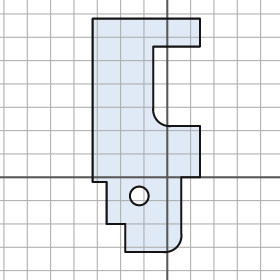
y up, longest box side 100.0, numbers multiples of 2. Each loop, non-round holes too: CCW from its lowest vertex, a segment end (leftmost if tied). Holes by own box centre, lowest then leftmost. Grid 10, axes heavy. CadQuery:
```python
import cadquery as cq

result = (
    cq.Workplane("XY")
    .moveTo(-18.0, -32.0)
    .lineTo(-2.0, -32.0)
    .threePointArc((4.0, -30.0), (6.0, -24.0))
    .lineTo(6.0, 0.0)
    .lineTo(14.0, 0.0)
    .lineTo(14.0, 22.0)
    .lineTo(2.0, 22.0)
    .threePointArc((-4.0, 24.0), (-6.0, 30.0))
    .lineTo(-6.0, 56.0)
    .lineTo(14.0, 56.0)
    .lineTo(14.0, 68.0)
    .lineTo(-32.0, 68.0)
    .lineTo(-32.0, -2.0)
    .lineTo(-26.0, -2.0)
    .lineTo(-26.0, -20.0)
    .lineTo(-18.0, -20.0)
    .close()
    .moveTo(-12.0, -8.0)
    .circle(4.0)
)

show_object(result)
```